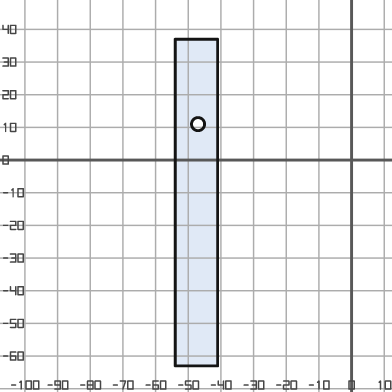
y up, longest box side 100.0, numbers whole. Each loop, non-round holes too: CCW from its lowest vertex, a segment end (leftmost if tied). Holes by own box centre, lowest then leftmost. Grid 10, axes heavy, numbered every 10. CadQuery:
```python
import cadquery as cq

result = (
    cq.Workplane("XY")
    .moveTo(-54.0, -63.0)
    .lineTo(-41.0, -63.0)
    .lineTo(-41.0, 37.0)
    .lineTo(-54.0, 37.0)
    .close()
    .moveTo(-47.0, 11.0)
    .circle(2.0)
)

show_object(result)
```